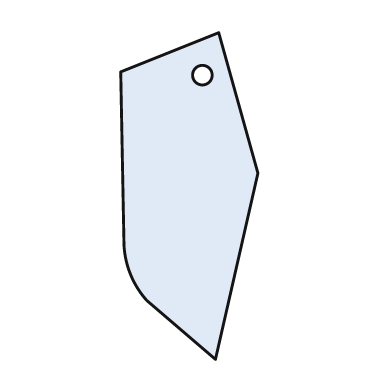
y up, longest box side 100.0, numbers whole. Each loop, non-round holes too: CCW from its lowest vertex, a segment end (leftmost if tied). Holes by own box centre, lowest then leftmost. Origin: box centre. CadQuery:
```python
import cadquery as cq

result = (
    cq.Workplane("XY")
    .moveTo(8.0, -50.0)
    .lineTo(21.0, 7.0)
    .lineTo(9.0, 50.0)
    .lineTo(-21.0, 38.0)
    .lineTo(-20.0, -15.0)
    .threePointArc((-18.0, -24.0), (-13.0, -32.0))
    .close()
    .moveTo(4.0, 37.0)
    .circle(3.0)
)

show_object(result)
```